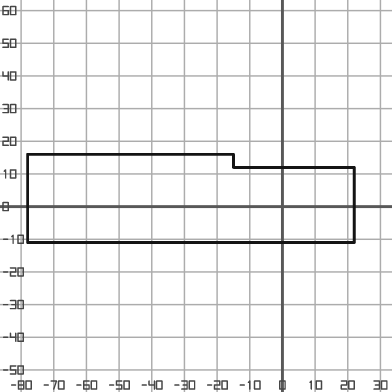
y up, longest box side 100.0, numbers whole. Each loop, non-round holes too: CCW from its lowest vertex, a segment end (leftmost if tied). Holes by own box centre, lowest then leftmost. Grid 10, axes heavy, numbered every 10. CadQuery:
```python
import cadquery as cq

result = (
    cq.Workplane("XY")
    .moveTo(-78.0, -11.0)
    .lineTo(22.0, -11.0)
    .lineTo(22.0, 12.0)
    .lineTo(-15.0, 12.0)
    .lineTo(-15.0, 16.0)
    .lineTo(-78.0, 16.0)
    .close()
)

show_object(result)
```